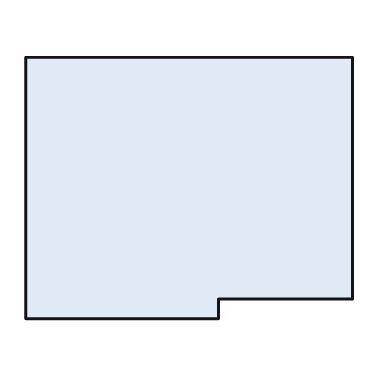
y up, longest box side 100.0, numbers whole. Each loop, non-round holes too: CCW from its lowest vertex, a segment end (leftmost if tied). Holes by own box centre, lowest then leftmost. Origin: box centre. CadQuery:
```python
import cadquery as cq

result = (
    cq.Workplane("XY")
    .moveTo(-50.0, -40.0)
    .lineTo(9.0, -40.0)
    .lineTo(9.0, -34.0)
    .lineTo(50.0, -34.0)
    .lineTo(50.0, 40.0)
    .lineTo(-50.0, 40.0)
    .close()
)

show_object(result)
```